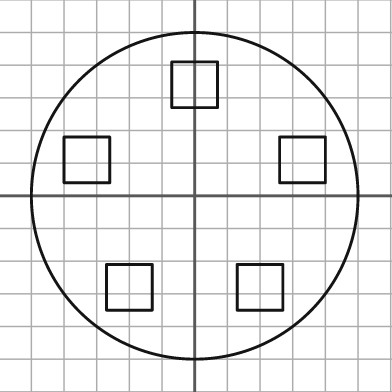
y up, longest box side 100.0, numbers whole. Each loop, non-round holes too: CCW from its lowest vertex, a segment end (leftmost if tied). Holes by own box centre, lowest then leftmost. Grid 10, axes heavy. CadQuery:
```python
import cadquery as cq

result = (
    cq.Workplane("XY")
    .moveTo(0.0, 0.0)
    .circle(50.0)
    .moveTo(-27.0, -35.0)
    .lineTo(-13.0, -35.0)
    .lineTo(-13.0, -21.0)
    .lineTo(-27.0, -21.0)
    .close()
    .moveTo(13.0, -35.0)
    .lineTo(27.0, -35.0)
    .lineTo(27.0, -21.0)
    .lineTo(13.0, -21.0)
    .close()
    .moveTo(-40.0, 4.0)
    .lineTo(-26.0, 4.0)
    .lineTo(-26.0, 18.0)
    .lineTo(-40.0, 18.0)
    .close()
    .moveTo(26.0, 4.0)
    .lineTo(40.0, 4.0)
    .lineTo(40.0, 18.0)
    .lineTo(26.0, 18.0)
    .close()
    .moveTo(-7.0, 27.0)
    .lineTo(7.0, 27.0)
    .lineTo(7.0, 41.0)
    .lineTo(-7.0, 41.0)
    .close()
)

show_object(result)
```